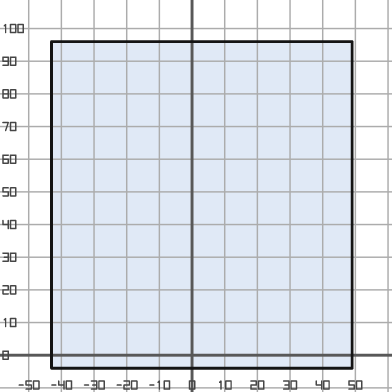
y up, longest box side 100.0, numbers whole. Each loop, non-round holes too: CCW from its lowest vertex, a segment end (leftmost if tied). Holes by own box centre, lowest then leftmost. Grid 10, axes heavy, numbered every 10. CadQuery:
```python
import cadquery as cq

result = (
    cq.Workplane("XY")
    .moveTo(-43.0, -4.0)
    .lineTo(49.0, -4.0)
    .lineTo(49.0, 96.0)
    .lineTo(-43.0, 96.0)
    .close()
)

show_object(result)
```